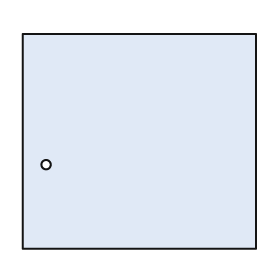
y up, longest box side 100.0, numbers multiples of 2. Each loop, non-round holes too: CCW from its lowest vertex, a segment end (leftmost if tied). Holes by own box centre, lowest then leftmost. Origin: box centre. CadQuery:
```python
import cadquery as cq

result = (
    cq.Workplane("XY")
    .moveTo(-50.0, -46.0)
    .lineTo(50.0, -46.0)
    .lineTo(50.0, 46.0)
    .lineTo(-50.0, 46.0)
    .close()
    .moveTo(-40.0, -10.0)
    .circle(2.0)
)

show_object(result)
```